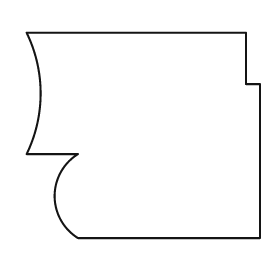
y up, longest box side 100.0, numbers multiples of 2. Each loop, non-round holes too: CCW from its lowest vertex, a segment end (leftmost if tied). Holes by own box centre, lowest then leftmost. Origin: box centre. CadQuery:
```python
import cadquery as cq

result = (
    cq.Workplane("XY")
    .moveTo(-28.0, -44.0)
    .lineTo(50.0, -44.0)
    .lineTo(50.0, 22.0)
    .lineTo(44.0, 22.0)
    .lineTo(44.0, 44.0)
    .lineTo(-50.0, 44.0)
    .threePointArc((-44.0, 18.0), (-50.0, -8.0))
    .lineTo(-28.0, -8.0)
    .threePointArc((-38.0, -26.0), (-28.0, -44.0))
    .close()
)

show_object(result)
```